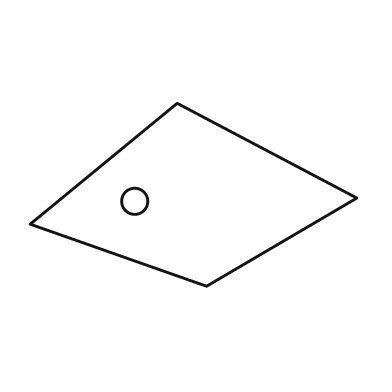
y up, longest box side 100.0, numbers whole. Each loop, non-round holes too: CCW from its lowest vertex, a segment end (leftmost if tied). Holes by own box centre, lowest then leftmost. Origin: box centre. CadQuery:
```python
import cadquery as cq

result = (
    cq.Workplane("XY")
    .moveTo(4.0, -28.0)
    .lineTo(50.0, -1.0)
    .lineTo(-5.0, 28.0)
    .lineTo(-50.0, -9.0)
    .close()
    .moveTo(-18.0, -2.0)
    .circle(4.0)
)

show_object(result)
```